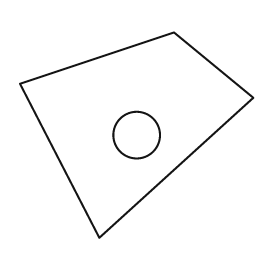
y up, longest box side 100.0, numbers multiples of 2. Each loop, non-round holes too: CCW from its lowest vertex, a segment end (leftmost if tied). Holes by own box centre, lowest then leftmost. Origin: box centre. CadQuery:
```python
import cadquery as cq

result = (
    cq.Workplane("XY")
    .moveTo(-16.0, -44.0)
    .lineTo(50.0, 16.0)
    .lineTo(16.0, 44.0)
    .lineTo(-50.0, 22.0)
    .close()
    .moveTo(0.0, 0.0)
    .circle(10.0)
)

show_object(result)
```